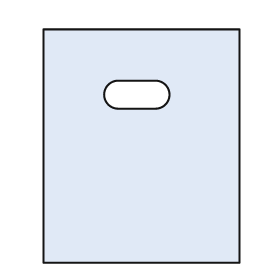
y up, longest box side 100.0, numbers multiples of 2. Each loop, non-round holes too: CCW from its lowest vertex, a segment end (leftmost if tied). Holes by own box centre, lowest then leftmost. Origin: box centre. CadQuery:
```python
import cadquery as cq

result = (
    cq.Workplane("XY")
    .moveTo(-42.0, -50.0)
    .lineTo(42.0, -50.0)
    .lineTo(42.0, 50.0)
    .lineTo(-42.0, 50.0)
    .close()
    .moveTo(-10.0, 16.0)
    .lineTo(6.0, 16.0)
    .threePointArc((12.0, 22.0), (6.0, 28.0))
    .lineTo(-10.0, 28.0)
    .threePointArc((-16.0, 22.0), (-10.0, 16.0))
    .close()
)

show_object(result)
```